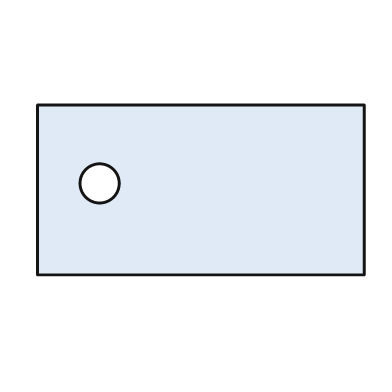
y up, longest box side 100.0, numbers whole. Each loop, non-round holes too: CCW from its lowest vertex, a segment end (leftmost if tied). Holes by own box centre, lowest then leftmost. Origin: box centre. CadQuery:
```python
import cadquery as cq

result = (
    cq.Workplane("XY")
    .moveTo(-50.0, -26.0)
    .lineTo(50.0, -26.0)
    .lineTo(50.0, 26.0)
    .lineTo(-50.0, 26.0)
    .close()
    .moveTo(-31.0, 2.0)
    .circle(6.0)
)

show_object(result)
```